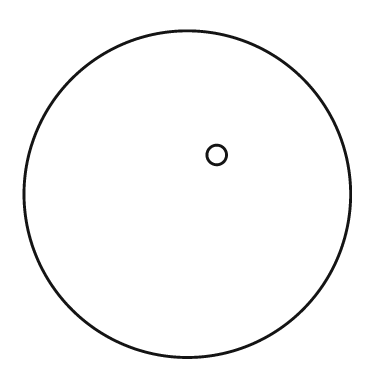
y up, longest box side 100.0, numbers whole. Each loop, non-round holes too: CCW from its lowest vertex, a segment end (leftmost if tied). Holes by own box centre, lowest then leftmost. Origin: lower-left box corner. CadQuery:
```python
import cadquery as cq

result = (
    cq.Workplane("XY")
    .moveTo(50.0, 50.0)
    .circle(50.0)
    .moveTo(59.0, 62.0)
    .circle(3.0)
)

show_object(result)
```